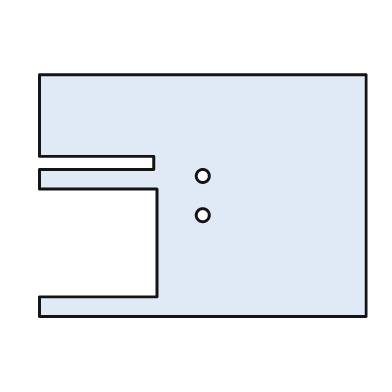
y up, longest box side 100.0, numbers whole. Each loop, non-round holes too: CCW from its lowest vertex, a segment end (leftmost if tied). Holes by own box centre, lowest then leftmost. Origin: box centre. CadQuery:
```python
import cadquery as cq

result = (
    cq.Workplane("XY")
    .moveTo(-50.0, -37.0)
    .lineTo(50.0, -37.0)
    .lineTo(50.0, 37.0)
    .lineTo(-50.0, 37.0)
    .lineTo(-50.0, 12.0)
    .lineTo(-15.0, 12.0)
    .lineTo(-15.0, 8.0)
    .lineTo(-50.0, 8.0)
    .lineTo(-50.0, 2.0)
    .lineTo(-14.0, 2.0)
    .lineTo(-14.0, -31.0)
    .lineTo(-50.0, -31.0)
    .close()
    .moveTo(0.0, -6.0)
    .circle(2.0)
    .moveTo(0.0, 6.0)
    .circle(2.0)
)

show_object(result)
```